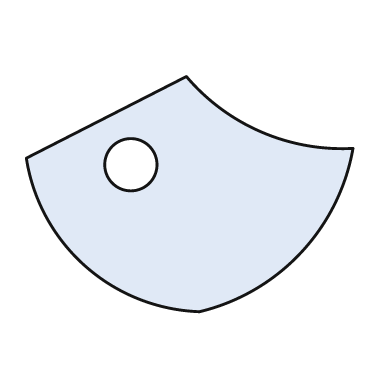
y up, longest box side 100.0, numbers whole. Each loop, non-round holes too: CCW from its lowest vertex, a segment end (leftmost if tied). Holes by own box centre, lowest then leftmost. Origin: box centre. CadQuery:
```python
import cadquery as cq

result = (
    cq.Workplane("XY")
    .moveTo(3.0, -36.0)
    .threePointArc((34.0, -18.0), (50.0, 14.0))
    .threePointArc((22.0, 19.0), (-1.0, 36.0))
    .lineTo(-50.0, 11.0)
    .threePointArc((-32.0, -22.0), (3.0, -36.0))
    .close()
    .moveTo(-18.0, 9.0)
    .circle(8.0)
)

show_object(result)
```